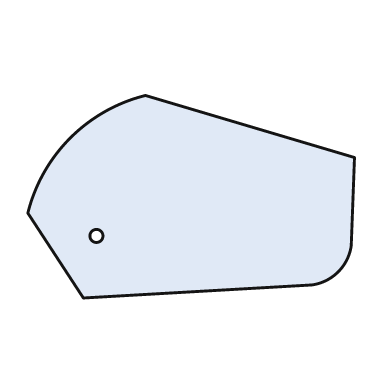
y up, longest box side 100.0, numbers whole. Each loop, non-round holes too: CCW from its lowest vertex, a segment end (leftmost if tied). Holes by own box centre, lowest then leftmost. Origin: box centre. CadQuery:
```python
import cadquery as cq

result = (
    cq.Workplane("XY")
    .moveTo(-33.0, -31.0)
    .lineTo(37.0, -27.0)
    .threePointArc((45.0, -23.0), (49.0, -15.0))
    .lineTo(50.0, 12.0)
    .lineTo(-14.0, 31.0)
    .threePointArc((-37.0, 18.0), (-50.0, -5.0))
    .close()
    .moveTo(-29.0, -12.0)
    .circle(2.0)
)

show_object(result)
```